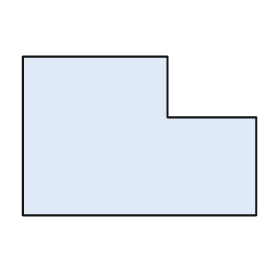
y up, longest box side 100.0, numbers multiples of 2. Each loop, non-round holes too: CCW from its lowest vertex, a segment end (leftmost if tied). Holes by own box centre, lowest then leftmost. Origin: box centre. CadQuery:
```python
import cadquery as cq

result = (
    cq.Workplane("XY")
    .moveTo(-50.0, -34.0)
    .lineTo(50.0, -34.0)
    .lineTo(50.0, 8.0)
    .lineTo(12.0, 8.0)
    .lineTo(12.0, 34.0)
    .lineTo(-50.0, 34.0)
    .close()
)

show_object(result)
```